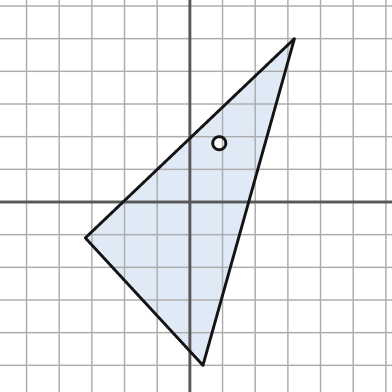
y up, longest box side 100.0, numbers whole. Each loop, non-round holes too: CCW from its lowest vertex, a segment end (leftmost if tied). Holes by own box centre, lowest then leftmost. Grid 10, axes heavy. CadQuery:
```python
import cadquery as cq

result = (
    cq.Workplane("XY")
    .moveTo(4.0, -50.0)
    .lineTo(32.0, 50.0)
    .lineTo(-32.0, -11.0)
    .close()
    .moveTo(9.0, 18.0)
    .circle(2.0)
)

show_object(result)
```